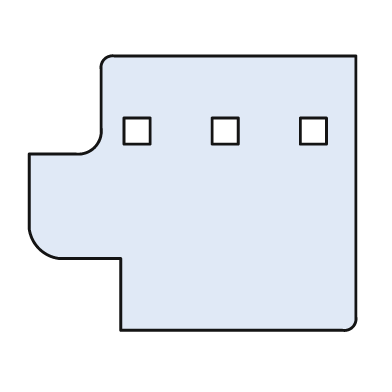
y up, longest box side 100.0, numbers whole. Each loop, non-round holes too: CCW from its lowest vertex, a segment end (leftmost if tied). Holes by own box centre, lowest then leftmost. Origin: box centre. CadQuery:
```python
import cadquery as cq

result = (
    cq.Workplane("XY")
    .moveTo(-22.0, -42.0)
    .lineTo(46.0, -42.0)
    .threePointArc((49.0, -41.0), (50.0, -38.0))
    .lineTo(50.0, 42.0)
    .lineTo(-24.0, 42.0)
    .threePointArc((-27.0, 41.0), (-28.0, 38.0))
    .lineTo(-28.0, 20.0)
    .threePointArc((-30.0, 14.0), (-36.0, 12.0))
    .lineTo(-50.0, 12.0)
    .lineTo(-50.0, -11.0)
    .threePointArc((-47.0, -17.0), (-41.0, -20.0))
    .lineTo(-22.0, -20.0)
    .close()
    .moveTo(-21.0, 15.0)
    .lineTo(-13.0, 15.0)
    .lineTo(-13.0, 23.0)
    .lineTo(-21.0, 23.0)
    .close()
    .moveTo(6.0, 15.0)
    .lineTo(14.0, 15.0)
    .lineTo(14.0, 23.0)
    .lineTo(6.0, 23.0)
    .close()
    .moveTo(33.0, 15.0)
    .lineTo(41.0, 15.0)
    .lineTo(41.0, 23.0)
    .lineTo(33.0, 23.0)
    .close()
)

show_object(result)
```